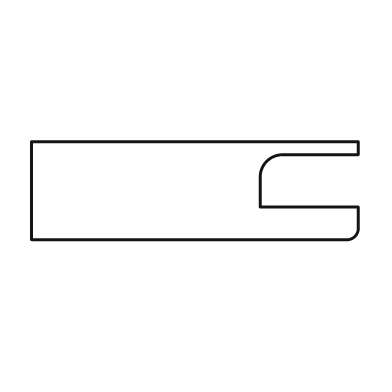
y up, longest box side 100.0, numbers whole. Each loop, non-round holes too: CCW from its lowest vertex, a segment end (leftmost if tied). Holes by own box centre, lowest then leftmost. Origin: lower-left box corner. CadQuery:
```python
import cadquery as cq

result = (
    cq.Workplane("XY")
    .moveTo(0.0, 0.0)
    .lineTo(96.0, 0.0)
    .threePointArc((99.0, 1.0), (100.0, 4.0))
    .lineTo(100.0, 10.0)
    .lineTo(70.0, 10.0)
    .lineTo(70.0, 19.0)
    .threePointArc((72.0, 24.0), (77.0, 26.0))
    .lineTo(100.0, 26.0)
    .lineTo(100.0, 30.0)
    .lineTo(0.0, 30.0)
    .close()
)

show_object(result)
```